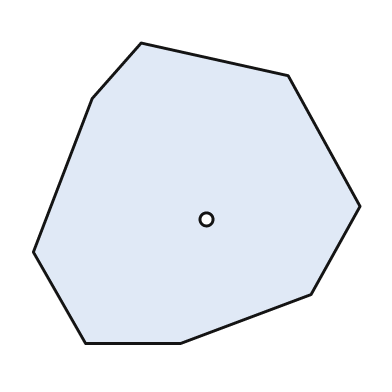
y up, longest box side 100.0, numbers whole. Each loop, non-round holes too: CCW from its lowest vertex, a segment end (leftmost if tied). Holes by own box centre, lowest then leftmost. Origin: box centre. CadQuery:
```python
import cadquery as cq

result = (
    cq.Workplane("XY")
    .moveTo(-34.0, -46.0)
    .lineTo(-5.0, -46.0)
    .lineTo(35.0, -31.0)
    .lineTo(50.0, -4.0)
    .lineTo(28.0, 36.0)
    .lineTo(-17.0, 46.0)
    .lineTo(-32.0, 29.0)
    .lineTo(-50.0, -18.0)
    .close()
    .moveTo(3.0, -8.0)
    .circle(2.0)
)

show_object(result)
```